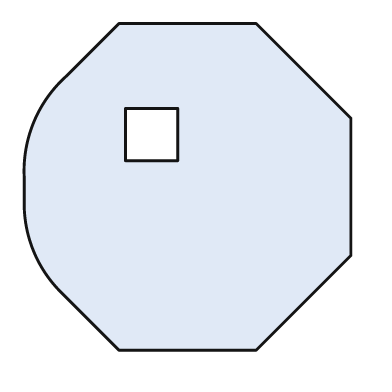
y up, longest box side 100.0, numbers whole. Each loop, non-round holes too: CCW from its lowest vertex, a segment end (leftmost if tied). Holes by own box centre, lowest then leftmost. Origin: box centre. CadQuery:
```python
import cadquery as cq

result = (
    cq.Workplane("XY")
    .moveTo(-21.0, -50.0)
    .lineTo(21.0, -50.0)
    .lineTo(50.0, -21.0)
    .lineTo(50.0, 21.0)
    .lineTo(21.0, 50.0)
    .lineTo(-21.0, 50.0)
    .lineTo(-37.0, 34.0)
    .threePointArc((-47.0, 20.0), (-50.0, 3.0))
    .lineTo(-50.0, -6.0)
    .threePointArc((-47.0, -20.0), (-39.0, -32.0))
    .close()
    .moveTo(-19.0, 8.0)
    .lineTo(-3.0, 8.0)
    .lineTo(-3.0, 24.0)
    .lineTo(-19.0, 24.0)
    .close()
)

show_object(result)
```